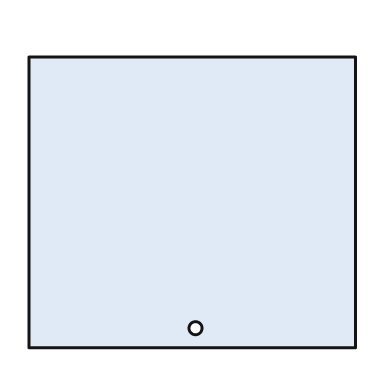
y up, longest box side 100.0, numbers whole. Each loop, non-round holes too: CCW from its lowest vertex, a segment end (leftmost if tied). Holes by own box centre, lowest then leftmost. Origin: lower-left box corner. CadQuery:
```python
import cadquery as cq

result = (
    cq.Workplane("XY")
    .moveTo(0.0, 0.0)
    .lineTo(100.0, 0.0)
    .lineTo(100.0, 89.0)
    .lineTo(0.0, 89.0)
    .close()
    .moveTo(51.0, 6.0)
    .circle(2.0)
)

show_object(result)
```